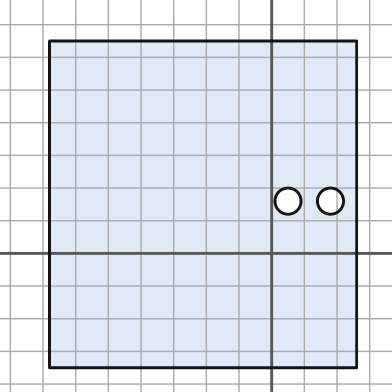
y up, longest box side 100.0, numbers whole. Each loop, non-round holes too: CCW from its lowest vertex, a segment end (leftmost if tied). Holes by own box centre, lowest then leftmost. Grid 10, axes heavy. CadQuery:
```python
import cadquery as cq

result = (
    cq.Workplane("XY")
    .moveTo(-68.0, -35.0)
    .lineTo(26.0, -35.0)
    .lineTo(26.0, 65.0)
    .lineTo(-68.0, 65.0)
    .close()
    .moveTo(5.0, 16.0)
    .circle(4.0)
    .moveTo(18.0, 16.0)
    .circle(4.0)
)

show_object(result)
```